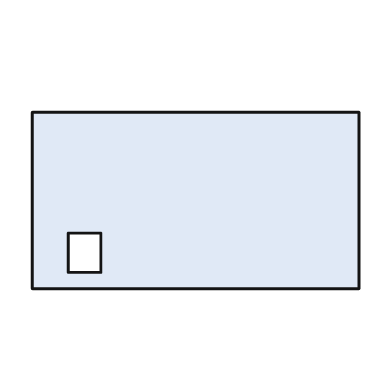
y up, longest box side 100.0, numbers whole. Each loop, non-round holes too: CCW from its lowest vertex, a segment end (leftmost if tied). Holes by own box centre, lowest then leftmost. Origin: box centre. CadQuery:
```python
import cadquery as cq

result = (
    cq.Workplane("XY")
    .moveTo(-50.0, -27.0)
    .lineTo(50.0, -27.0)
    .lineTo(50.0, 27.0)
    .lineTo(-50.0, 27.0)
    .close()
    .moveTo(-39.0, -22.0)
    .lineTo(-29.0, -22.0)
    .lineTo(-29.0, -10.0)
    .lineTo(-39.0, -10.0)
    .close()
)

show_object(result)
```